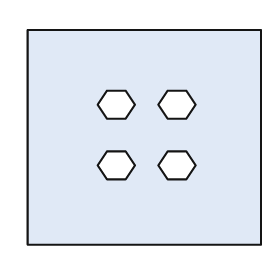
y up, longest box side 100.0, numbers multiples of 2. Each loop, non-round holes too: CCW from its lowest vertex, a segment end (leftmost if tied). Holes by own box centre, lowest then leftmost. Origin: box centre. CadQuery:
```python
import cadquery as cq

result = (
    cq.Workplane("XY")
    .moveTo(-50.0, -46.0)
    .lineTo(50.0, -46.0)
    .lineTo(50.0, 46.0)
    .lineTo(-50.0, 46.0)
    .close()
    .moveTo(-16.0, -18.0)
    .lineTo(-8.0, -18.0)
    .lineTo(-4.0, -12.0)
    .lineTo(-8.0, -6.0)
    .lineTo(-16.0, -6.0)
    .lineTo(-20.0, -12.0)
    .close()
    .moveTo(10.0, -18.0)
    .lineTo(18.0, -18.0)
    .lineTo(22.0, -12.0)
    .lineTo(18.0, -6.0)
    .lineTo(10.0, -6.0)
    .lineTo(6.0, -12.0)
    .close()
    .moveTo(-16.0, 8.0)
    .lineTo(-8.0, 8.0)
    .lineTo(-4.0, 14.0)
    .lineTo(-8.0, 20.0)
    .lineTo(-16.0, 20.0)
    .lineTo(-20.0, 14.0)
    .close()
    .moveTo(10.0, 8.0)
    .lineTo(18.0, 8.0)
    .lineTo(22.0, 14.0)
    .lineTo(18.0, 20.0)
    .lineTo(10.0, 20.0)
    .lineTo(6.0, 14.0)
    .close()
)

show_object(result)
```